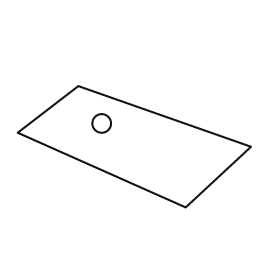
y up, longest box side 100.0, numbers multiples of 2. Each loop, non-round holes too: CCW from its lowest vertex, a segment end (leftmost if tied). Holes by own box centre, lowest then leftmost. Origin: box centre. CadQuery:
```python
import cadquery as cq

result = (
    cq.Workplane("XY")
    .moveTo(22.0, -26.0)
    .lineTo(50.0, 0.0)
    .lineTo(-24.0, 26.0)
    .lineTo(-50.0, 6.0)
    .close()
    .moveTo(-14.0, 10.0)
    .circle(4.0)
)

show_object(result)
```